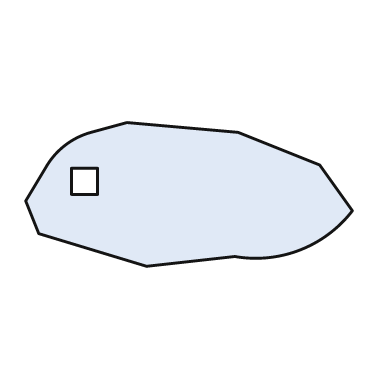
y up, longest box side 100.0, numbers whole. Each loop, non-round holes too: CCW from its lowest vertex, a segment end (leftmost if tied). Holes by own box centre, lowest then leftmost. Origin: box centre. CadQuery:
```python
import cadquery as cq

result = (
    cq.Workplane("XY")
    .moveTo(-13.0, -22.0)
    .lineTo(14.0, -19.0)
    .threePointArc((34.0, -17.0), (50.0, -5.0))
    .lineTo(40.0, 9.0)
    .lineTo(15.0, 19.0)
    .lineTo(-19.0, 22.0)
    .lineTo(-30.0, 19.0)
    .threePointArc((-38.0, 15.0), (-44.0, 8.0))
    .lineTo(-50.0, -2.0)
    .lineTo(-46.0, -12.0)
    .close()
    .moveTo(-36.0, 0.0)
    .lineTo(-28.0, 0.0)
    .lineTo(-28.0, 8.0)
    .lineTo(-36.0, 8.0)
    .close()
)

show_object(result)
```